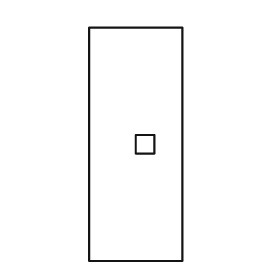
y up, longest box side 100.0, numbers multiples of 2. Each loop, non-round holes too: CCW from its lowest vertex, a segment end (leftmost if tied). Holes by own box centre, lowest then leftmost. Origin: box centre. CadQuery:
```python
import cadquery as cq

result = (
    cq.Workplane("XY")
    .moveTo(-20.0, -50.0)
    .lineTo(20.0, -50.0)
    .lineTo(20.0, 50.0)
    .lineTo(-20.0, 50.0)
    .close()
    .moveTo(0.0, -4.0)
    .lineTo(8.0, -4.0)
    .lineTo(8.0, 4.0)
    .lineTo(0.0, 4.0)
    .close()
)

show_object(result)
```